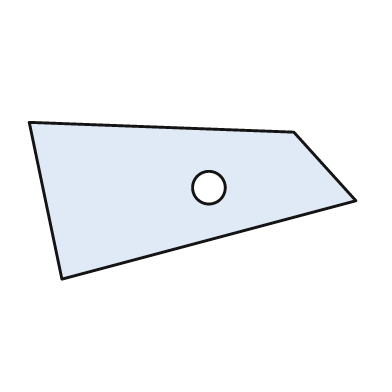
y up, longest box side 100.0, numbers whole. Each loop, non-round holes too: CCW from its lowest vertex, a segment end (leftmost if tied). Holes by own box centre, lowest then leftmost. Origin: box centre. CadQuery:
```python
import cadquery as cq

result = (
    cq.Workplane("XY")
    .moveTo(-40.0, -24.0)
    .lineTo(50.0, 0.0)
    .lineTo(31.0, 21.0)
    .lineTo(-50.0, 24.0)
    .close()
    .moveTo(5.0, 4.0)
    .circle(5.0)
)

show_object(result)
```